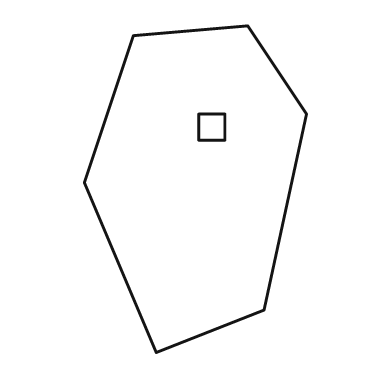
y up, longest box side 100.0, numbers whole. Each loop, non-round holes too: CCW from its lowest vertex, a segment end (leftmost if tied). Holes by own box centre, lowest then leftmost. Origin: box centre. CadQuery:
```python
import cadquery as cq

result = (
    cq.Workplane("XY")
    .moveTo(-12.0, -50.0)
    .lineTo(21.0, -37.0)
    .lineTo(34.0, 23.0)
    .lineTo(16.0, 50.0)
    .lineTo(-19.0, 47.0)
    .lineTo(-34.0, 2.0)
    .close()
    .moveTo(1.0, 15.0)
    .lineTo(9.0, 15.0)
    .lineTo(9.0, 23.0)
    .lineTo(1.0, 23.0)
    .close()
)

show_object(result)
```